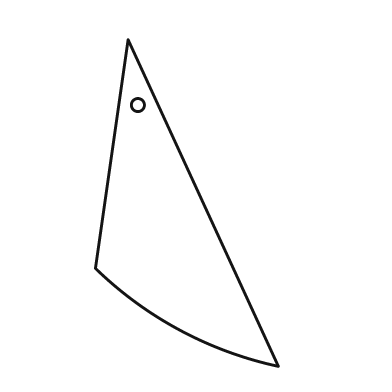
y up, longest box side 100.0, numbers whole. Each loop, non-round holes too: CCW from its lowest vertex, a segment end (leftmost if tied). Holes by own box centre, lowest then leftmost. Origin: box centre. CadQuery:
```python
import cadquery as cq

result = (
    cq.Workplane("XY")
    .moveTo(28.0, -50.0)
    .lineTo(-18.0, 50.0)
    .lineTo(-28.0, -20.0)
    .threePointArc((-2.0, -39.0), (28.0, -50.0))
    .close()
    .moveTo(-15.0, 30.0)
    .circle(2.0)
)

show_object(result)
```